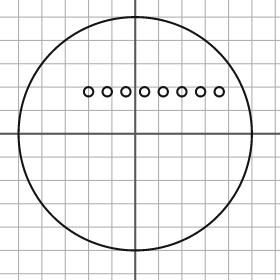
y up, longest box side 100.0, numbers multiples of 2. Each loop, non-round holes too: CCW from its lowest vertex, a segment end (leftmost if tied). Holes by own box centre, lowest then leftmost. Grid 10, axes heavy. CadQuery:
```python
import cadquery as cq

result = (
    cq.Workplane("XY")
    .moveTo(0.0, 0.0)
    .circle(50.0)
    .moveTo(-20.0, 18.0)
    .circle(2.0)
    .moveTo(-12.0, 18.0)
    .circle(2.0)
    .moveTo(-4.0, 18.0)
    .circle(2.0)
    .moveTo(4.0, 18.0)
    .circle(2.0)
    .moveTo(12.0, 18.0)
    .circle(2.0)
    .moveTo(20.0, 18.0)
    .circle(2.0)
    .moveTo(28.0, 18.0)
    .circle(2.0)
    .moveTo(36.0, 18.0)
    .circle(2.0)
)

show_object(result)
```